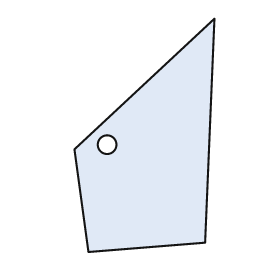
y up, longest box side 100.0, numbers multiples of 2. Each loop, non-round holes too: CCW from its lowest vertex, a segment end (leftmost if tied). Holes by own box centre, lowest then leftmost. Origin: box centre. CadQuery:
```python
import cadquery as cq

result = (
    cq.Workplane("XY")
    .moveTo(-24.0, -50.0)
    .lineTo(26.0, -46.0)
    .lineTo(30.0, 50.0)
    .lineTo(-30.0, -6.0)
    .close()
    .moveTo(-16.0, -4.0)
    .circle(4.0)
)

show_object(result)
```